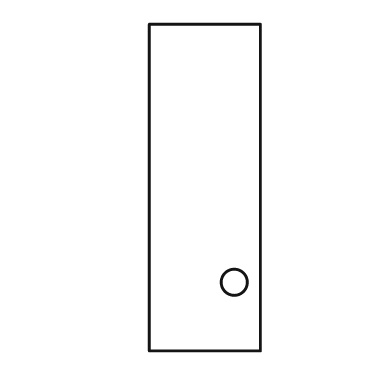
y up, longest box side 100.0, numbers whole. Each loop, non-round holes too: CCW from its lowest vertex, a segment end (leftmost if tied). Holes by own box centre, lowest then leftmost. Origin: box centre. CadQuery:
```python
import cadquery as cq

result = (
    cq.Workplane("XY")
    .moveTo(-17.0, -50.0)
    .lineTo(17.0, -50.0)
    .lineTo(17.0, 50.0)
    .lineTo(-17.0, 50.0)
    .close()
    .moveTo(9.0, -29.0)
    .circle(4.0)
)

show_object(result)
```